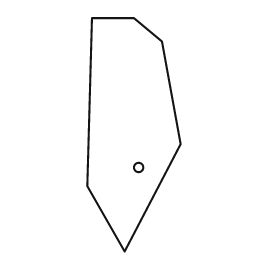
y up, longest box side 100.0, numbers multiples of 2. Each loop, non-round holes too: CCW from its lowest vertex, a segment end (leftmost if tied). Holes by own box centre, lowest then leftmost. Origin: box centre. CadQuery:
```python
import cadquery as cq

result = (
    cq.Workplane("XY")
    .moveTo(-4.0, -50.0)
    .lineTo(20.0, -4.0)
    .lineTo(12.0, 40.0)
    .lineTo(0.0, 50.0)
    .lineTo(-18.0, 50.0)
    .lineTo(-20.0, -22.0)
    .close()
    .moveTo(2.0, -14.0)
    .circle(2.0)
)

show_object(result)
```